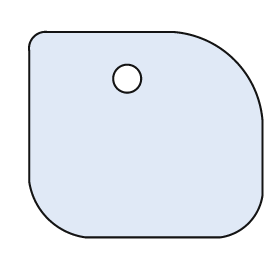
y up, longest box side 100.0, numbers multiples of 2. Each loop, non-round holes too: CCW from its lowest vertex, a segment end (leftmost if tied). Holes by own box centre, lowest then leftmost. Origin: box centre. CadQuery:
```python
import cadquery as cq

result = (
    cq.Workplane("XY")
    .moveTo(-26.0, -44.0)
    .lineTo(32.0, -44.0)
    .threePointArc((44.0, -38.0), (50.0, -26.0))
    .lineTo(50.0, 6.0)
    .threePointArc((38.0, 32.0), (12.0, 44.0))
    .lineTo(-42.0, 44.0)
    .threePointArc((-48.0, 42.0), (-50.0, 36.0))
    .lineTo(-50.0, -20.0)
    .threePointArc((-42.0, -36.0), (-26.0, -44.0))
    .close()
    .moveTo(-8.0, 24.0)
    .circle(6.0)
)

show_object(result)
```